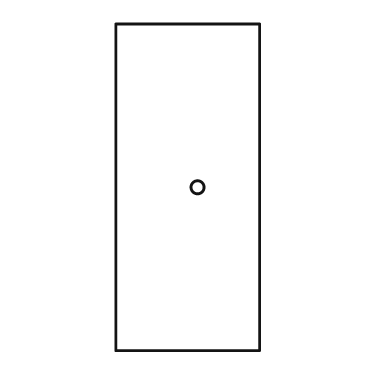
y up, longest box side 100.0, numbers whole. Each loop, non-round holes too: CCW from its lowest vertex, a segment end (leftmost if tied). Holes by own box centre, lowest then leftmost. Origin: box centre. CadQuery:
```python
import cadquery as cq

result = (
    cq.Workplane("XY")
    .moveTo(-22.0, -50.0)
    .lineTo(22.0, -50.0)
    .lineTo(22.0, 50.0)
    .lineTo(-22.0, 50.0)
    .close()
    .moveTo(3.0, 0.0)
    .circle(2.0)
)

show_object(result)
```